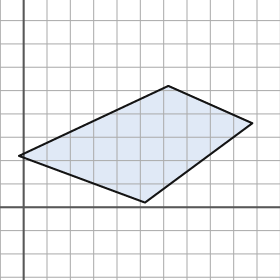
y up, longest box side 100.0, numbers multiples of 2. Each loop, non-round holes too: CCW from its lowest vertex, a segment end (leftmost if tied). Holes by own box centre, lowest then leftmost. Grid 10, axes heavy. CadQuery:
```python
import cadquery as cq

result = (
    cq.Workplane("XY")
    .moveTo(52.0, 2.0)
    .lineTo(98.0, 36.0)
    .lineTo(62.0, 52.0)
    .lineTo(-2.0, 22.0)
    .close()
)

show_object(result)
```